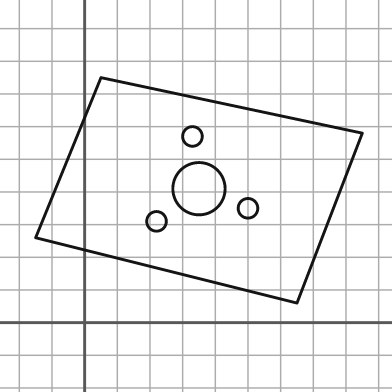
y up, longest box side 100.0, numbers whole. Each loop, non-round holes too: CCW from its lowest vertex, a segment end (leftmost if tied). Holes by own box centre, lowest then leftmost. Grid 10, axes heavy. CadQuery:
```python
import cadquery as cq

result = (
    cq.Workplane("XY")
    .moveTo(65.0, 6.0)
    .lineTo(85.0, 58.0)
    .lineTo(5.0, 75.0)
    .lineTo(-15.0, 26.0)
    .close()
    .moveTo(22.0, 31.0)
    .circle(3.0)
    .moveTo(50.0, 35.0)
    .circle(3.0)
    .moveTo(35.0, 41.0)
    .circle(8.0)
    .moveTo(33.0, 57.0)
    .circle(3.0)
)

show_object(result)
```